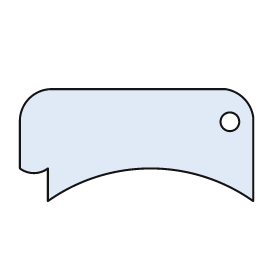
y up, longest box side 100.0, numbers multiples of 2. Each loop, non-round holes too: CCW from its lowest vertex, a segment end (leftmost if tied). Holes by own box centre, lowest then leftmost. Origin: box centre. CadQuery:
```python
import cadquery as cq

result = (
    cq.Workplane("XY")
    .moveTo(-38.0, -24.0)
    .threePointArc((6.0, -10.0), (50.0, -24.0))
    .lineTo(50.0, 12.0)
    .threePointArc((46.0, 20.0), (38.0, 24.0))
    .lineTo(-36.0, 24.0)
    .threePointArc((-46.0, 20.0), (-50.0, 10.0))
    .lineTo(-50.0, -10.0)
    .threePointArc((-44.0, -12.0), (-38.0, -10.0))
    .close()
    .moveTo(40.0, 10.0)
    .circle(4.0)
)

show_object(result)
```